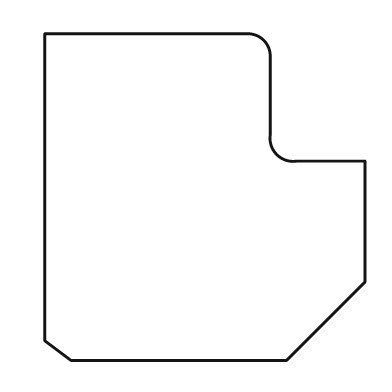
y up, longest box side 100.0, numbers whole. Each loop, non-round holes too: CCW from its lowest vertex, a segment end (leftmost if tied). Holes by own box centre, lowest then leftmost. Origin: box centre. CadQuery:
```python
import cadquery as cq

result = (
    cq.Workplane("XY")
    .moveTo(-41.0, -50.0)
    .lineTo(25.0, -50.0)
    .lineTo(49.0, -26.0)
    .lineTo(49.0, 11.0)
    .lineTo(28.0, 11.0)
    .threePointArc((22.0, 13.0), (20.0, 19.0))
    .lineTo(20.0, 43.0)
    .threePointArc((18.0, 48.0), (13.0, 50.0))
    .lineTo(-49.0, 50.0)
    .lineTo(-49.0, -44.0)
    .close()
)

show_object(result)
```